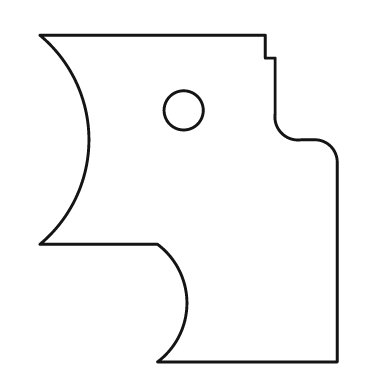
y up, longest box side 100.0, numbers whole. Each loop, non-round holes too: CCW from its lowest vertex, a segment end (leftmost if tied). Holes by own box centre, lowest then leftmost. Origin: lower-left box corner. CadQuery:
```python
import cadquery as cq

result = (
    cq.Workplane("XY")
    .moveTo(36.0, 0.0)
    .lineTo(91.0, 0.0)
    .lineTo(91.0, 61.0)
    .threePointArc((89.0, 66.0), (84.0, 68.0))
    .lineTo(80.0, 68.0)
    .threePointArc((74.0, 70.0), (72.0, 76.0))
    .lineTo(72.0, 93.0)
    .lineTo(69.0, 93.0)
    .lineTo(69.0, 100.0)
    .lineTo(0.0, 100.0)
    .threePointArc((15.0, 68.0), (0.0, 36.0))
    .lineTo(36.0, 36.0)
    .threePointArc((45.0, 18.0), (36.0, 0.0))
    .close()
    .moveTo(44.0, 77.0)
    .circle(6.0)
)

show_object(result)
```